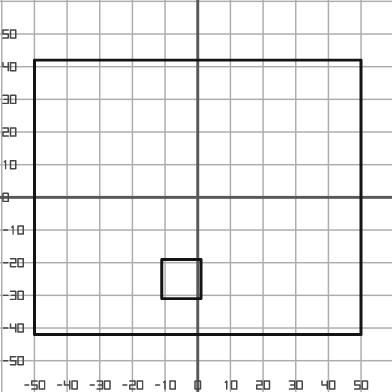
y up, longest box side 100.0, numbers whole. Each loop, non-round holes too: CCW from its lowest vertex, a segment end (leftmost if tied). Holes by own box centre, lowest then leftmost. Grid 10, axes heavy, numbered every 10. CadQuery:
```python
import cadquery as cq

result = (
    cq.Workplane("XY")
    .moveTo(-50.0, -42.0)
    .lineTo(50.0, -42.0)
    .lineTo(50.0, 42.0)
    .lineTo(-50.0, 42.0)
    .close()
    .moveTo(-11.0, -31.0)
    .lineTo(1.0, -31.0)
    .lineTo(1.0, -19.0)
    .lineTo(-11.0, -19.0)
    .close()
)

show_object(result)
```